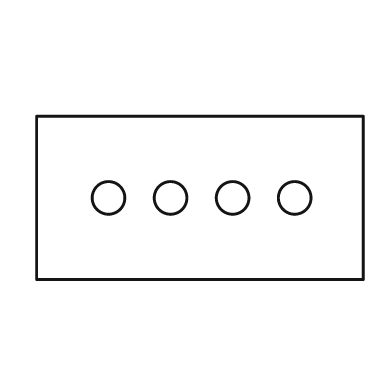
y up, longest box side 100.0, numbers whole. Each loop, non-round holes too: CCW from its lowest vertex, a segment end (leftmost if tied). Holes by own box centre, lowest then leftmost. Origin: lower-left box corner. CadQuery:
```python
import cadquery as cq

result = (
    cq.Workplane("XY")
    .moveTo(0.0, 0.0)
    .lineTo(100.0, 0.0)
    .lineTo(100.0, 50.0)
    .lineTo(0.0, 50.0)
    .close()
    .moveTo(22.0, 25.0)
    .circle(5.0)
    .moveTo(41.0, 25.0)
    .circle(5.0)
    .moveTo(60.0, 25.0)
    .circle(5.0)
    .moveTo(79.0, 25.0)
    .circle(5.0)
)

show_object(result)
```